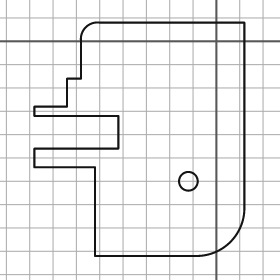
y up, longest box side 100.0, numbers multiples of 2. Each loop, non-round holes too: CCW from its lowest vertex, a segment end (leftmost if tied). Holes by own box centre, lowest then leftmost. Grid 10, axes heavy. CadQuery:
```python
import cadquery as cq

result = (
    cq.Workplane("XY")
    .moveTo(-52.0, -92.0)
    .lineTo(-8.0, -92.0)
    .threePointArc((6.0, -86.0), (12.0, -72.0))
    .lineTo(12.0, 8.0)
    .lineTo(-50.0, 8.0)
    .threePointArc((-56.0, 6.0), (-58.0, 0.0))
    .lineTo(-58.0, -16.0)
    .lineTo(-64.0, -16.0)
    .lineTo(-64.0, -28.0)
    .lineTo(-78.0, -28.0)
    .lineTo(-78.0, -32.0)
    .lineTo(-42.0, -32.0)
    .lineTo(-42.0, -46.0)
    .lineTo(-78.0, -46.0)
    .lineTo(-78.0, -54.0)
    .lineTo(-52.0, -54.0)
    .close()
    .moveTo(-12.0, -60.0)
    .circle(4.0)
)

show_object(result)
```